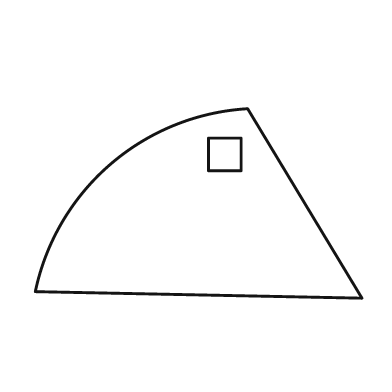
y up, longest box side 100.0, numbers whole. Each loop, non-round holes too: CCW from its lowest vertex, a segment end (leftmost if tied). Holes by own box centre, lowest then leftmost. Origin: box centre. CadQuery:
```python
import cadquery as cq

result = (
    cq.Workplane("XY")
    .moveTo(50.0, -29.0)
    .lineTo(15.0, 29.0)
    .threePointArc((-27.0, 12.0), (-50.0, -27.0))
    .close()
    .moveTo(3.0, 10.0)
    .lineTo(13.0, 10.0)
    .lineTo(13.0, 20.0)
    .lineTo(3.0, 20.0)
    .close()
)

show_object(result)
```